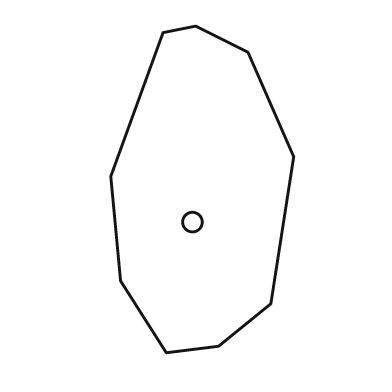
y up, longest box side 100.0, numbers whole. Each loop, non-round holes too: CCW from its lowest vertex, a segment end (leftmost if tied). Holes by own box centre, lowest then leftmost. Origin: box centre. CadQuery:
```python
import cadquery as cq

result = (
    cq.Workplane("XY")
    .moveTo(-11.0, -50.0)
    .lineTo(5.0, -48.0)
    .lineTo(21.0, -35.0)
    .lineTo(28.0, 10.0)
    .lineTo(14.0, 42.0)
    .lineTo(-2.0, 50.0)
    .lineTo(-12.0, 48.0)
    .lineTo(-28.0, 4.0)
    .lineTo(-25.0, -28.0)
    .close()
    .moveTo(-3.0, -10.0)
    .circle(3.0)
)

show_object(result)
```